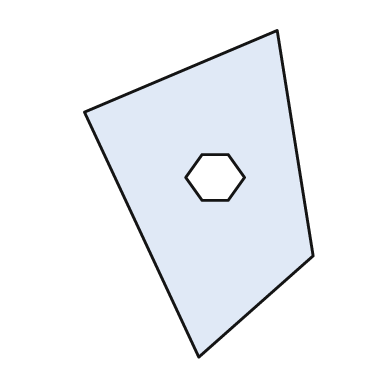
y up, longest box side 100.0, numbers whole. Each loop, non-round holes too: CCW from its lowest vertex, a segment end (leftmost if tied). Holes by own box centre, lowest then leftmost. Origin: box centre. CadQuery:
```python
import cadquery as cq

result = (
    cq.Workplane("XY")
    .moveTo(0.0, -50.0)
    .lineTo(35.0, -19.0)
    .lineTo(24.0, 50.0)
    .lineTo(-35.0, 25.0)
    .close()
    .moveTo(1.0, -2.0)
    .lineTo(9.0, -2.0)
    .lineTo(14.0, 5.0)
    .lineTo(9.0, 12.0)
    .lineTo(1.0, 12.0)
    .lineTo(-4.0, 5.0)
    .close()
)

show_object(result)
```